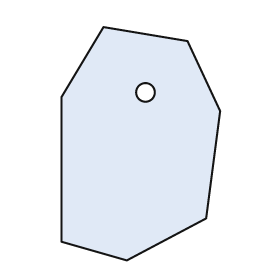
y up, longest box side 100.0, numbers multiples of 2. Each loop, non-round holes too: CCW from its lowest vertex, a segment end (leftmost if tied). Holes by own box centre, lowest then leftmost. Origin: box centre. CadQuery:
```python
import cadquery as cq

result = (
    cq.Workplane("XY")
    .moveTo(-6.0, -50.0)
    .lineTo(28.0, -32.0)
    .lineTo(34.0, 14.0)
    .lineTo(20.0, 44.0)
    .lineTo(-16.0, 50.0)
    .lineTo(-34.0, 20.0)
    .lineTo(-34.0, -42.0)
    .close()
    .moveTo(2.0, 22.0)
    .circle(4.0)
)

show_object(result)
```